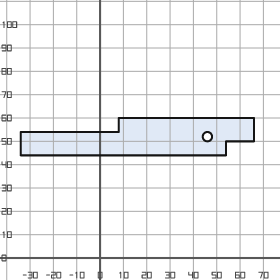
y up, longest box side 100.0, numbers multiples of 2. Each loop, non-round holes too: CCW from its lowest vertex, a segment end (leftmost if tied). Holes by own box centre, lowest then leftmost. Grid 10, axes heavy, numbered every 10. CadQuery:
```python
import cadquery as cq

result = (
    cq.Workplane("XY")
    .moveTo(-34.0, 44.0)
    .lineTo(54.0, 44.0)
    .lineTo(54.0, 50.0)
    .lineTo(66.0, 50.0)
    .lineTo(66.0, 60.0)
    .lineTo(8.0, 60.0)
    .lineTo(8.0, 54.0)
    .lineTo(-34.0, 54.0)
    .close()
    .moveTo(46.0, 52.0)
    .circle(2.0)
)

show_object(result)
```